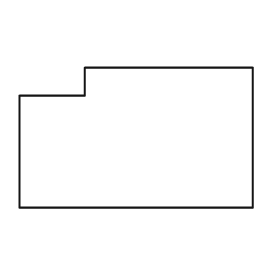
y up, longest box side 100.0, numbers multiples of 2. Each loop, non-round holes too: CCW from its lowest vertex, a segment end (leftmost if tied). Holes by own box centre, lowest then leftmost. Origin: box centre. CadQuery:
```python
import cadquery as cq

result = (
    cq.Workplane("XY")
    .moveTo(-50.0, -30.0)
    .lineTo(50.0, -30.0)
    .lineTo(50.0, 30.0)
    .lineTo(-22.0, 30.0)
    .lineTo(-22.0, 18.0)
    .lineTo(-50.0, 18.0)
    .close()
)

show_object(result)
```